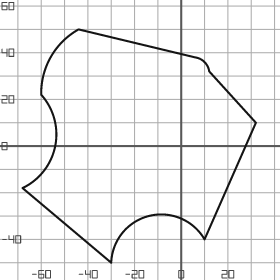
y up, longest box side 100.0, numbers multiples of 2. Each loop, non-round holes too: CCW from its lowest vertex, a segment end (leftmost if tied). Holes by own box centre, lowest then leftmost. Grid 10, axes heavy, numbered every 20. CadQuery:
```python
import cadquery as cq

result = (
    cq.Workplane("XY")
    .moveTo(-30.0, -50.0)
    .threePointArc((-14.0, -30.0), (10.0, -40.0))
    .lineTo(32.0, 10.0)
    .lineTo(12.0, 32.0)
    .threePointArc((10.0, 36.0), (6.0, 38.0))
    .lineTo(-44.0, 50.0)
    .threePointArc((-56.0, 38.0), (-60.0, 22.0))
    .threePointArc((-54.0, 0.0), (-68.0, -18.0))
    .close()
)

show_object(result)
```